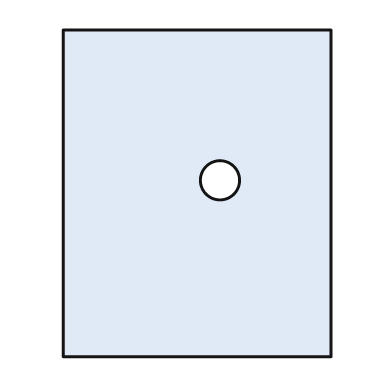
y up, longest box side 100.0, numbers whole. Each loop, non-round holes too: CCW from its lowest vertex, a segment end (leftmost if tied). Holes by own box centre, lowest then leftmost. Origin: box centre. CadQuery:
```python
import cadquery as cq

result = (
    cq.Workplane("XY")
    .moveTo(-41.0, -50.0)
    .lineTo(41.0, -50.0)
    .lineTo(41.0, 50.0)
    .lineTo(-41.0, 50.0)
    .close()
    .moveTo(7.0, 4.0)
    .circle(6.0)
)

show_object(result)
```